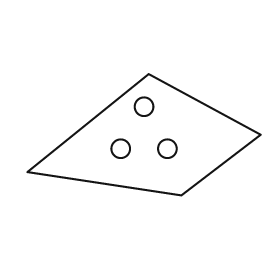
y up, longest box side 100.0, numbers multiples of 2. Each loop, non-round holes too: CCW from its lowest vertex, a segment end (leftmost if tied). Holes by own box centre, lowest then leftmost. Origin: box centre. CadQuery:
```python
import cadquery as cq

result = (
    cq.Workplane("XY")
    .moveTo(16.0, -26.0)
    .lineTo(50.0, 0.0)
    .lineTo(2.0, 26.0)
    .lineTo(-50.0, -16.0)
    .close()
    .moveTo(-10.0, -6.0)
    .circle(4.0)
    .moveTo(10.0, -6.0)
    .circle(4.0)
    .moveTo(0.0, 12.0)
    .circle(4.0)
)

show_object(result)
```